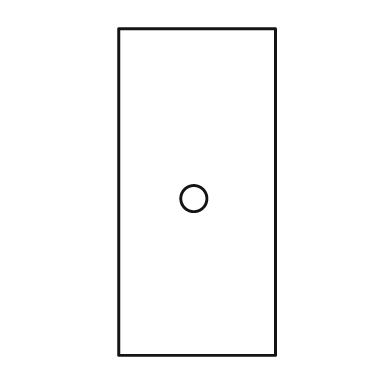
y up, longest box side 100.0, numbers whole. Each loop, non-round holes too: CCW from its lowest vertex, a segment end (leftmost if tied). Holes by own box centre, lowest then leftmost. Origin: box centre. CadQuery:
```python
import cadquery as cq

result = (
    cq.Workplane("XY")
    .moveTo(-24.0, -50.0)
    .lineTo(24.0, -50.0)
    .lineTo(24.0, 50.0)
    .lineTo(-24.0, 50.0)
    .close()
    .moveTo(-1.0, -2.0)
    .circle(4.0)
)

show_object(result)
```